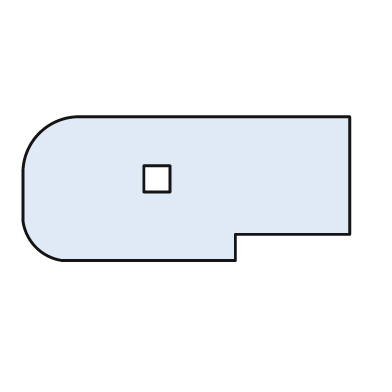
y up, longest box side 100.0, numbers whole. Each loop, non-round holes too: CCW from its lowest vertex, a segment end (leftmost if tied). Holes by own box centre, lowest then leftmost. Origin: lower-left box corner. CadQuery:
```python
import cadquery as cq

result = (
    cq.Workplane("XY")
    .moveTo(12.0, 0.0)
    .lineTo(65.0, 0.0)
    .lineTo(65.0, 8.0)
    .lineTo(100.0, 8.0)
    .lineTo(100.0, 44.0)
    .lineTo(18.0, 44.0)
    .threePointArc((5.0, 39.0), (0.0, 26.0))
    .lineTo(0.0, 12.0)
    .threePointArc((4.0, 4.0), (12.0, 0.0))
    .close()
    .moveTo(37.0, 21.0)
    .lineTo(45.0, 21.0)
    .lineTo(45.0, 29.0)
    .lineTo(37.0, 29.0)
    .close()
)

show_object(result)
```